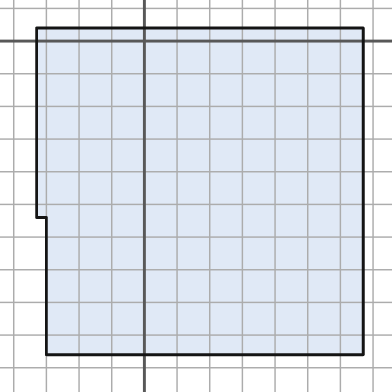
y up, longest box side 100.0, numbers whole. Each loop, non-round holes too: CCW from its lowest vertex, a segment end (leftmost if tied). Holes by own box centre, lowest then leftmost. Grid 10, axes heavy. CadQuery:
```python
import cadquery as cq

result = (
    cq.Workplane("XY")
    .moveTo(-30.0, -96.0)
    .lineTo(67.0, -96.0)
    .lineTo(67.0, 4.0)
    .lineTo(-33.0, 4.0)
    .lineTo(-33.0, -54.0)
    .lineTo(-30.0, -54.0)
    .close()
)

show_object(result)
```